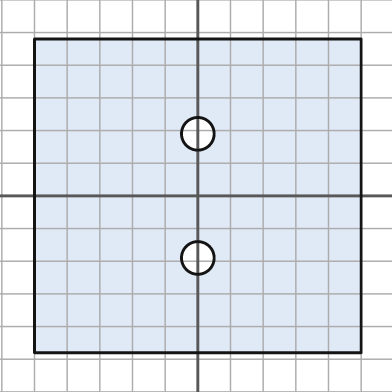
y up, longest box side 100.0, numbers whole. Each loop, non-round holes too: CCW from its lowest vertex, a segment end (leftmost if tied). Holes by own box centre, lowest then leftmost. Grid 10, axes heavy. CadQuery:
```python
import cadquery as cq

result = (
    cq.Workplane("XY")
    .moveTo(-50.0, -48.0)
    .lineTo(50.0, -48.0)
    .lineTo(50.0, 48.0)
    .lineTo(-50.0, 48.0)
    .close()
    .moveTo(0.0, -19.0)
    .circle(5.0)
    .moveTo(0.0, 19.0)
    .circle(5.0)
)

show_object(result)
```